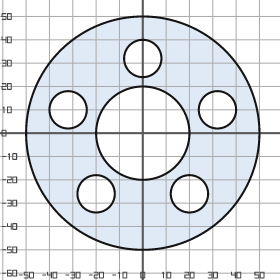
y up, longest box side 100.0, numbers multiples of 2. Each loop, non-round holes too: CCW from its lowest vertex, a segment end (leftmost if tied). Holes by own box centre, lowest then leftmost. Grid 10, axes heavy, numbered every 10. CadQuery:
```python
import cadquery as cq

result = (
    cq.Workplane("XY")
    .moveTo(0.0, 0.0)
    .circle(50.0)
    .moveTo(-20.0, -26.0)
    .circle(8.0)
    .moveTo(20.0, -26.0)
    .circle(8.0)
    .moveTo(0.0, 0.0)
    .circle(20.0)
    .moveTo(-32.0, 10.0)
    .circle(8.0)
    .moveTo(32.0, 10.0)
    .circle(8.0)
    .moveTo(0.0, 32.0)
    .circle(8.0)
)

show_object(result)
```